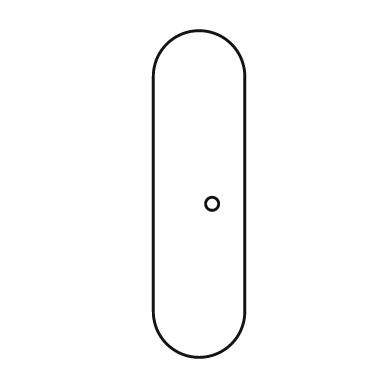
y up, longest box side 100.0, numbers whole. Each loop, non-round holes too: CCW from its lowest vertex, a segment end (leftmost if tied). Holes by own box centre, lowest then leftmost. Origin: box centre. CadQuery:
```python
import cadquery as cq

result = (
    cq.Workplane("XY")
    .moveTo(-14.0, -36.0)
    .threePointArc((0.0, -50.0), (14.0, -36.0))
    .lineTo(14.0, 36.0)
    .threePointArc((0.0, 50.0), (-14.0, 36.0))
    .close()
    .moveTo(4.0, -3.0)
    .circle(2.0)
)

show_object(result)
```